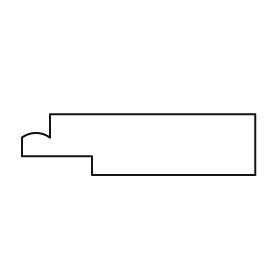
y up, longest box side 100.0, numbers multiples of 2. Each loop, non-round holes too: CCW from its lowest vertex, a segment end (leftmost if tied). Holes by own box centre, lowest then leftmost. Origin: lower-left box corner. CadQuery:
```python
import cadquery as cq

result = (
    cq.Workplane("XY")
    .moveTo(30.0, 0.0)
    .lineTo(100.0, 0.0)
    .lineTo(100.0, 26.0)
    .lineTo(12.0, 26.0)
    .lineTo(12.0, 16.0)
    .threePointArc((6.0, 18.0), (0.0, 16.0))
    .lineTo(0.0, 8.0)
    .lineTo(30.0, 8.0)
    .close()
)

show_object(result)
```